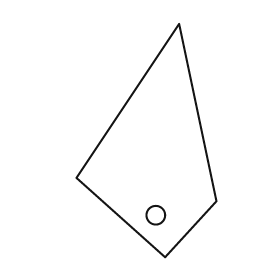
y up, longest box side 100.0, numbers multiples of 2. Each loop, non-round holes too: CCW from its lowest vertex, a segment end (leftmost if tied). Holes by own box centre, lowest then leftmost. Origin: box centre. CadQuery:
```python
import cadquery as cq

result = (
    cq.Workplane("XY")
    .moveTo(8.0, -50.0)
    .lineTo(30.0, -26.0)
    .lineTo(14.0, 50.0)
    .lineTo(-30.0, -16.0)
    .close()
    .moveTo(4.0, -32.0)
    .circle(4.0)
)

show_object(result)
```